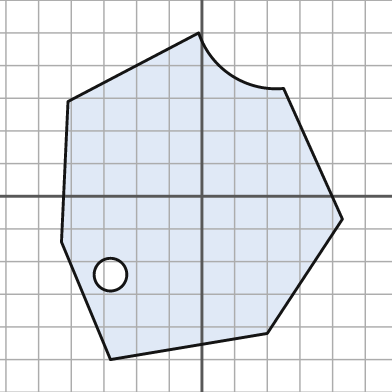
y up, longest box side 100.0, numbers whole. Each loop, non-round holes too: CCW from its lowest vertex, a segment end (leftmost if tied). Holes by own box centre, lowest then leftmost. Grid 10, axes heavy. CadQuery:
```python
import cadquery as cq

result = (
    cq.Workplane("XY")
    .moveTo(-28.0, -50.0)
    .lineTo(20.0, -42.0)
    .lineTo(43.0, -7.0)
    .lineTo(25.0, 33.0)
    .threePointArc((9.0, 37.0), (-1.0, 50.0))
    .lineTo(-41.0, 29.0)
    .lineTo(-43.0, -14.0)
    .close()
    .moveTo(-28.0, -24.0)
    .circle(5.0)
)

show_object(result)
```